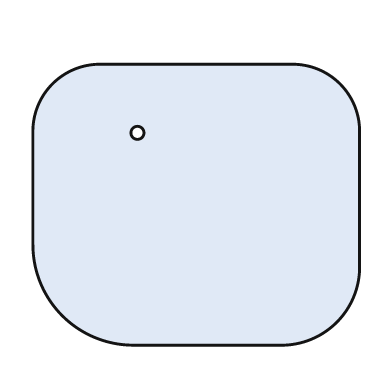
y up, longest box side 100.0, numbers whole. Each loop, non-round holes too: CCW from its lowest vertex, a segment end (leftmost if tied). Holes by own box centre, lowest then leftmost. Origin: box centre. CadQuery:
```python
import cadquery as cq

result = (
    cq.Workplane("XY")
    .moveTo(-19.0, -43.0)
    .lineTo(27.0, -43.0)
    .threePointArc((43.0, -36.0), (50.0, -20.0))
    .lineTo(50.0, 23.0)
    .threePointArc((44.0, 37.0), (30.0, 43.0))
    .lineTo(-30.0, 43.0)
    .threePointArc((-44.0, 37.0), (-50.0, 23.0))
    .lineTo(-50.0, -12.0)
    .threePointArc((-41.0, -34.0), (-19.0, -43.0))
    .close()
    .moveTo(-18.0, 22.0)
    .circle(2.0)
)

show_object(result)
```